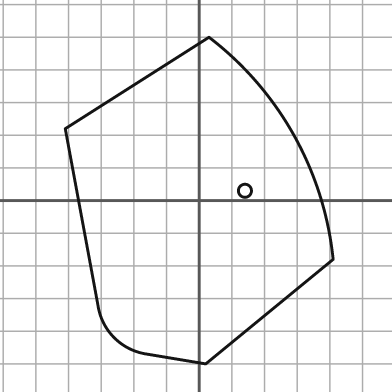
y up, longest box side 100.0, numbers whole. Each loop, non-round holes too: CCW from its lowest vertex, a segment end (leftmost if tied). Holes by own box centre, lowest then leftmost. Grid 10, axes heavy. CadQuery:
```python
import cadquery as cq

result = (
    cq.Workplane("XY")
    .moveTo(2.0, -50.0)
    .lineTo(41.0, -18.0)
    .threePointArc((29.0, 20.0), (3.0, 50.0))
    .lineTo(-41.0, 22.0)
    .lineTo(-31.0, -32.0)
    .threePointArc((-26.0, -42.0), (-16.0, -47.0))
    .close()
    .moveTo(14.0, 3.0)
    .circle(2.0)
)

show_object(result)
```